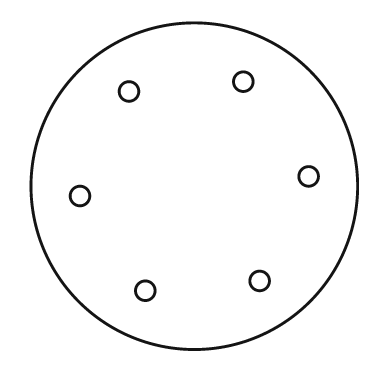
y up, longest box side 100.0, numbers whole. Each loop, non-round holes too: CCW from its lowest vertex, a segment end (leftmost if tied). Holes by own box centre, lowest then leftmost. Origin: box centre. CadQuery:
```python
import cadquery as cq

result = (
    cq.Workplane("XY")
    .moveTo(0.0, 0.0)
    .circle(50.0)
    .moveTo(-15.0, -32.0)
    .circle(3.0)
    .moveTo(20.0, -29.0)
    .circle(3.0)
    .moveTo(-35.0, -3.0)
    .circle(3.0)
    .moveTo(35.0, 3.0)
    .circle(3.0)
    .moveTo(-20.0, 29.0)
    .circle(3.0)
    .moveTo(15.0, 32.0)
    .circle(3.0)
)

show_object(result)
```